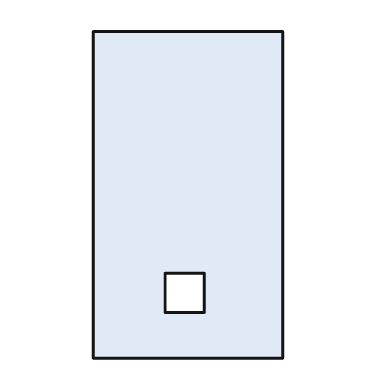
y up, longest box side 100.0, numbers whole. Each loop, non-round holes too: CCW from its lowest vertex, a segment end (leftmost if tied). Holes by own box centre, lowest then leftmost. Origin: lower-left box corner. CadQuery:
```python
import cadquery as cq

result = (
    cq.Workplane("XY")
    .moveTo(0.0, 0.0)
    .lineTo(58.0, 0.0)
    .lineTo(58.0, 100.0)
    .lineTo(0.0, 100.0)
    .close()
    .moveTo(22.0, 14.0)
    .lineTo(34.0, 14.0)
    .lineTo(34.0, 26.0)
    .lineTo(22.0, 26.0)
    .close()
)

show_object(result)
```